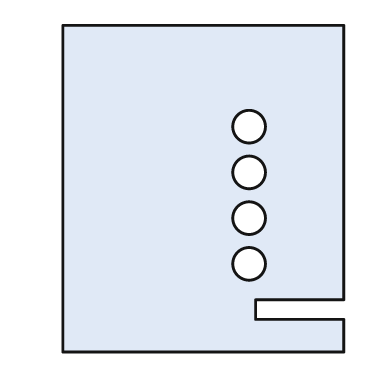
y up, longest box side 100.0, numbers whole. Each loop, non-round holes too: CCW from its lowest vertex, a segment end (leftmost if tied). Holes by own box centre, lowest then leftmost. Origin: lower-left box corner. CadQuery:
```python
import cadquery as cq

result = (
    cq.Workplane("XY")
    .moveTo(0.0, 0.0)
    .lineTo(86.0, 0.0)
    .lineTo(86.0, 10.0)
    .lineTo(59.0, 10.0)
    .lineTo(59.0, 16.0)
    .lineTo(86.0, 16.0)
    .lineTo(86.0, 100.0)
    .lineTo(0.0, 100.0)
    .close()
    .moveTo(57.0, 27.0)
    .circle(5.0)
    .moveTo(57.0, 41.0)
    .circle(5.0)
    .moveTo(57.0, 55.0)
    .circle(5.0)
    .moveTo(57.0, 69.0)
    .circle(5.0)
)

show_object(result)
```